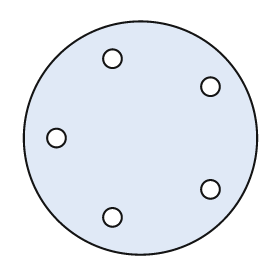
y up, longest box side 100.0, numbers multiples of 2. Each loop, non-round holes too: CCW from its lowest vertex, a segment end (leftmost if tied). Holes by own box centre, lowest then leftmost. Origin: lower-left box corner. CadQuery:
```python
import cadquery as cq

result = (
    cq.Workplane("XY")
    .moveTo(50.0, 50.0)
    .circle(50.0)
    .moveTo(38.0, 16.0)
    .circle(4.0)
    .moveTo(80.0, 28.0)
    .circle(4.0)
    .moveTo(14.0, 50.0)
    .circle(4.0)
    .moveTo(80.0, 72.0)
    .circle(4.0)
    .moveTo(38.0, 84.0)
    .circle(4.0)
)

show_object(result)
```